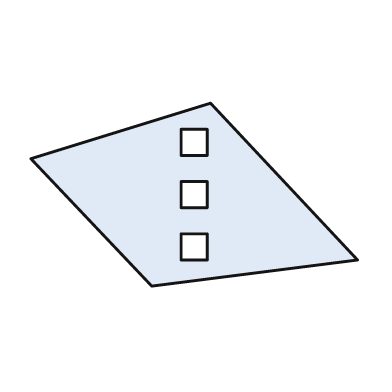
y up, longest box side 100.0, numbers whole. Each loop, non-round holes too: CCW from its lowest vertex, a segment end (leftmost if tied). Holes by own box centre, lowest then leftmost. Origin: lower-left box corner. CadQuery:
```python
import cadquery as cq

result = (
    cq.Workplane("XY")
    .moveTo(37.0, 0.0)
    .lineTo(100.0, 8.0)
    .lineTo(55.0, 56.0)
    .lineTo(0.0, 39.0)
    .close()
    .moveTo(46.0, 8.0)
    .lineTo(54.0, 8.0)
    .lineTo(54.0, 16.0)
    .lineTo(46.0, 16.0)
    .close()
    .moveTo(46.0, 24.0)
    .lineTo(54.0, 24.0)
    .lineTo(54.0, 32.0)
    .lineTo(46.0, 32.0)
    .close()
    .moveTo(46.0, 40.0)
    .lineTo(54.0, 40.0)
    .lineTo(54.0, 48.0)
    .lineTo(46.0, 48.0)
    .close()
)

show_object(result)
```